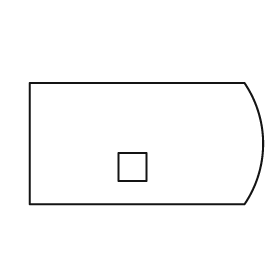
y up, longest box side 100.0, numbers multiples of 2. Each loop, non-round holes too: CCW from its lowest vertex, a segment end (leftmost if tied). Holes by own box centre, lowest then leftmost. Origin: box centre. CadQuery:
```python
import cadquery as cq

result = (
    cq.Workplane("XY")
    .moveTo(-50.0, -26.0)
    .lineTo(42.0, -26.0)
    .threePointArc((50.0, 0.0), (42.0, 26.0))
    .lineTo(-50.0, 26.0)
    .close()
    .moveTo(-12.0, -16.0)
    .lineTo(0.0, -16.0)
    .lineTo(0.0, -4.0)
    .lineTo(-12.0, -4.0)
    .close()
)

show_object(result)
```